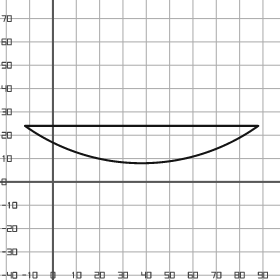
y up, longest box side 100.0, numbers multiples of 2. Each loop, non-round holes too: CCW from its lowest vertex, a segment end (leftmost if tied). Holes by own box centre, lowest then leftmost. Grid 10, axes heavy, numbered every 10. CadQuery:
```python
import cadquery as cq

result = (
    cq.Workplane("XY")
    .moveTo(-12.0, 24.0)
    .threePointArc((38.0, 8.0), (88.0, 24.0))
    .close()
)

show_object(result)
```